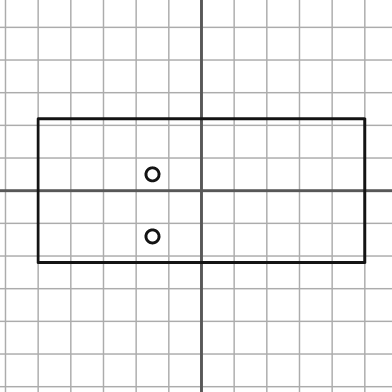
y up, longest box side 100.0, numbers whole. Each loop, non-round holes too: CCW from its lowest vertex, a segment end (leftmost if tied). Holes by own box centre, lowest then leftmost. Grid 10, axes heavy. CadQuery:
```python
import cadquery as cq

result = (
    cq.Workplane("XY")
    .moveTo(-50.0, -22.0)
    .lineTo(50.0, -22.0)
    .lineTo(50.0, 22.0)
    .lineTo(-50.0, 22.0)
    .close()
    .moveTo(-15.0, -14.0)
    .circle(2.0)
    .moveTo(-15.0, 5.0)
    .circle(2.0)
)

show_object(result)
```